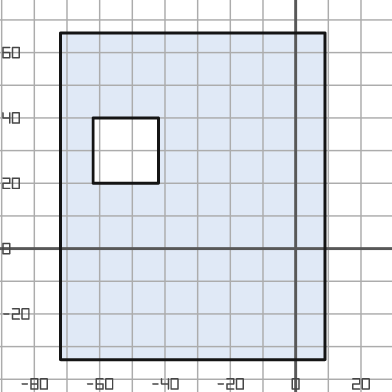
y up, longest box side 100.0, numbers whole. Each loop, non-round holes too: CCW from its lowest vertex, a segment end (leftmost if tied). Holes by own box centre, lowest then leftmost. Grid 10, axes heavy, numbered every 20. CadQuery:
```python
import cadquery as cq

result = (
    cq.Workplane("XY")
    .moveTo(-72.0, -34.0)
    .lineTo(9.0, -34.0)
    .lineTo(9.0, 66.0)
    .lineTo(-72.0, 66.0)
    .close()
    .moveTo(-62.0, 20.0)
    .lineTo(-42.0, 20.0)
    .lineTo(-42.0, 40.0)
    .lineTo(-62.0, 40.0)
    .close()
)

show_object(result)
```